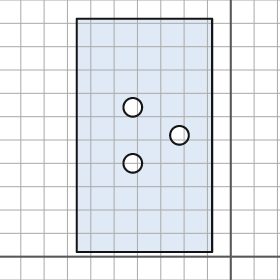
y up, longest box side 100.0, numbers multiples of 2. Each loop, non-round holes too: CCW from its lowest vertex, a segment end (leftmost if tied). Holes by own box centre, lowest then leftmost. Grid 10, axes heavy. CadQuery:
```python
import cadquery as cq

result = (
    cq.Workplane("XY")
    .moveTo(-66.0, 2.0)
    .lineTo(-8.0, 2.0)
    .lineTo(-8.0, 102.0)
    .lineTo(-66.0, 102.0)
    .close()
    .moveTo(-42.0, 40.0)
    .circle(4.0)
    .moveTo(-22.0, 52.0)
    .circle(4.0)
    .moveTo(-42.0, 64.0)
    .circle(4.0)
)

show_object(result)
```